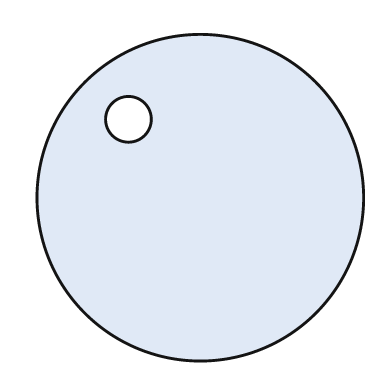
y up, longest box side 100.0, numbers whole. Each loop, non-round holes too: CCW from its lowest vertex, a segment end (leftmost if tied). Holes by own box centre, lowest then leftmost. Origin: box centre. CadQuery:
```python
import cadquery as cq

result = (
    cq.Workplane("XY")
    .moveTo(0.0, 0.0)
    .circle(50.0)
    .moveTo(-22.0, 24.0)
    .circle(7.0)
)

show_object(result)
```